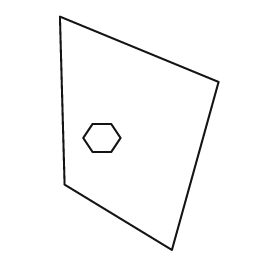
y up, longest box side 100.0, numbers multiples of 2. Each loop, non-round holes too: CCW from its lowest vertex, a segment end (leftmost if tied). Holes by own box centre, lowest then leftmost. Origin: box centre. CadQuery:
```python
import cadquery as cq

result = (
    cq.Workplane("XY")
    .moveTo(14.0, -50.0)
    .lineTo(34.0, 22.0)
    .lineTo(-34.0, 50.0)
    .lineTo(-32.0, -22.0)
    .close()
    .moveTo(-20.0, -8.0)
    .lineTo(-12.0, -8.0)
    .lineTo(-8.0, -2.0)
    .lineTo(-12.0, 4.0)
    .lineTo(-20.0, 4.0)
    .lineTo(-24.0, -2.0)
    .close()
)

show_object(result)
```